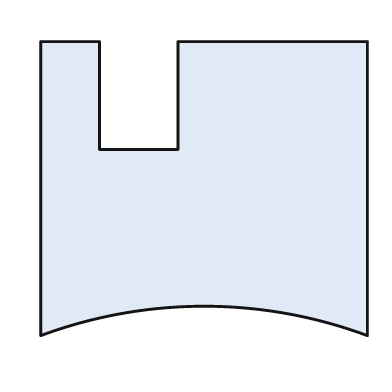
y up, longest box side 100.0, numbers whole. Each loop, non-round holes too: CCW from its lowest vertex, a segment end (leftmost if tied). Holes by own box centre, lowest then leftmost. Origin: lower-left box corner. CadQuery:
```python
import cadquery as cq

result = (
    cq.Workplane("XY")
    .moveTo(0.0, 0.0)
    .threePointArc((50.0, 9.0), (100.0, 0.0))
    .lineTo(100.0, 90.0)
    .lineTo(42.0, 90.0)
    .lineTo(42.0, 57.0)
    .lineTo(18.0, 57.0)
    .lineTo(18.0, 90.0)
    .lineTo(0.0, 90.0)
    .close()
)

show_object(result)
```